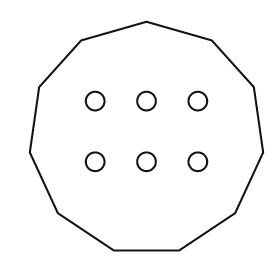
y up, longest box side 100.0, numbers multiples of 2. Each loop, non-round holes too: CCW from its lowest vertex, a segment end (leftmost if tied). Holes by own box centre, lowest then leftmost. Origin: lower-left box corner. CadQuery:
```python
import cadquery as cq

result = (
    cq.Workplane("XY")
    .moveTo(36.0, 0.0)
    .lineTo(64.0, 0.0)
    .lineTo(88.0, 16.0)
    .lineTo(100.0, 42.0)
    .lineTo(96.0, 70.0)
    .lineTo(78.0, 90.0)
    .lineTo(50.0, 98.0)
    .lineTo(22.0, 90.0)
    .lineTo(4.0, 70.0)
    .lineTo(0.0, 42.0)
    .lineTo(12.0, 16.0)
    .close()
    .moveTo(28.0, 38.0)
    .circle(4.0)
    .moveTo(50.0, 38.0)
    .circle(4.0)
    .moveTo(72.0, 38.0)
    .circle(4.0)
    .moveTo(28.0, 64.0)
    .circle(4.0)
    .moveTo(50.0, 64.0)
    .circle(4.0)
    .moveTo(72.0, 64.0)
    .circle(4.0)
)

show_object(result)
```